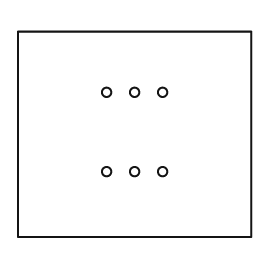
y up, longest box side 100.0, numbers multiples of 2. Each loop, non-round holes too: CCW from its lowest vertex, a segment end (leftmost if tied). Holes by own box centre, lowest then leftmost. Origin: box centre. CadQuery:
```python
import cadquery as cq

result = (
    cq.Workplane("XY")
    .moveTo(-50.0, -44.0)
    .lineTo(50.0, -44.0)
    .lineTo(50.0, 44.0)
    .lineTo(-50.0, 44.0)
    .close()
    .moveTo(-12.0, -16.0)
    .circle(2.0)
    .moveTo(0.0, -16.0)
    .circle(2.0)
    .moveTo(12.0, -16.0)
    .circle(2.0)
    .moveTo(-12.0, 18.0)
    .circle(2.0)
    .moveTo(0.0, 18.0)
    .circle(2.0)
    .moveTo(12.0, 18.0)
    .circle(2.0)
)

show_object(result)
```